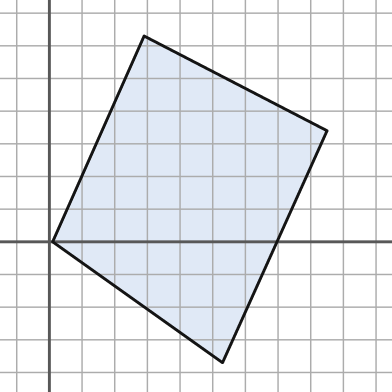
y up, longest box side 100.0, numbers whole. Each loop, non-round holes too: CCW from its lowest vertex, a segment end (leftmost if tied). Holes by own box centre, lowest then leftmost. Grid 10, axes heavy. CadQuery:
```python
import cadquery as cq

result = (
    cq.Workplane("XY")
    .moveTo(53.0, -37.0)
    .lineTo(85.0, 34.0)
    .lineTo(29.0, 63.0)
    .lineTo(1.0, 0.0)
    .close()
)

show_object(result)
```